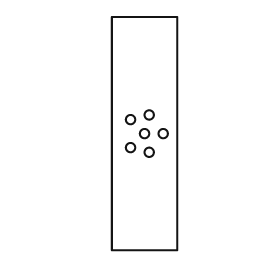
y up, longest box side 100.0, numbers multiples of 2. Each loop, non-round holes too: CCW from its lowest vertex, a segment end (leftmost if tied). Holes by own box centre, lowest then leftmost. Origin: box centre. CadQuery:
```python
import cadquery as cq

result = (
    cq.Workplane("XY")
    .moveTo(-14.0, -50.0)
    .lineTo(14.0, -50.0)
    .lineTo(14.0, 50.0)
    .lineTo(-14.0, 50.0)
    .close()
    .moveTo(2.0, -8.0)
    .circle(2.0)
    .moveTo(-6.0, -6.0)
    .circle(2.0)
    .moveTo(0.0, 0.0)
    .circle(2.0)
    .moveTo(8.0, 0.0)
    .circle(2.0)
    .moveTo(-6.0, 6.0)
    .circle(2.0)
    .moveTo(2.0, 8.0)
    .circle(2.0)
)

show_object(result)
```